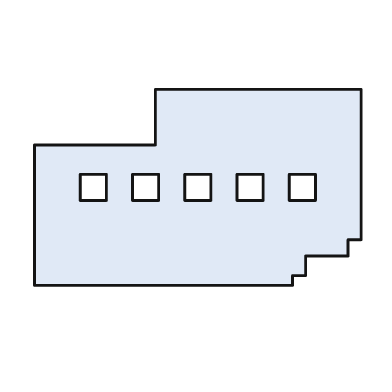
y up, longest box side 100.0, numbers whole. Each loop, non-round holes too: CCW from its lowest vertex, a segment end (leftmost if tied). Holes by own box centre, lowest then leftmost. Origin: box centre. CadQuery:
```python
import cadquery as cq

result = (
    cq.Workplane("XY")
    .moveTo(-50.0, -30.0)
    .lineTo(29.0, -30.0)
    .lineTo(29.0, -27.0)
    .lineTo(33.0, -27.0)
    .lineTo(33.0, -21.0)
    .lineTo(46.0, -21.0)
    .lineTo(46.0, -16.0)
    .lineTo(50.0, -16.0)
    .lineTo(50.0, 30.0)
    .lineTo(-13.0, 30.0)
    .lineTo(-13.0, 13.0)
    .lineTo(-50.0, 13.0)
    .close()
    .moveTo(-36.0, -4.0)
    .lineTo(-28.0, -4.0)
    .lineTo(-28.0, 4.0)
    .lineTo(-36.0, 4.0)
    .close()
    .moveTo(-20.0, -4.0)
    .lineTo(-12.0, -4.0)
    .lineTo(-12.0, 4.0)
    .lineTo(-20.0, 4.0)
    .close()
    .moveTo(-4.0, -4.0)
    .lineTo(4.0, -4.0)
    .lineTo(4.0, 4.0)
    .lineTo(-4.0, 4.0)
    .close()
    .moveTo(12.0, -4.0)
    .lineTo(20.0, -4.0)
    .lineTo(20.0, 4.0)
    .lineTo(12.0, 4.0)
    .close()
    .moveTo(28.0, -4.0)
    .lineTo(36.0, -4.0)
    .lineTo(36.0, 4.0)
    .lineTo(28.0, 4.0)
    .close()
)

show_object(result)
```